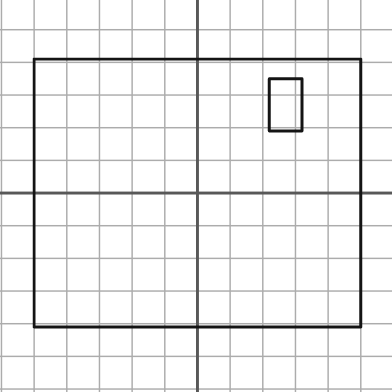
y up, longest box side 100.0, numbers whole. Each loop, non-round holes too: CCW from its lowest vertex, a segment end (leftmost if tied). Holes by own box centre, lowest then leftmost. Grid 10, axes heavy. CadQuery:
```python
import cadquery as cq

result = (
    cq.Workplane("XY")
    .moveTo(-50.0, -41.0)
    .lineTo(50.0, -41.0)
    .lineTo(50.0, 41.0)
    .lineTo(-50.0, 41.0)
    .close()
    .moveTo(22.0, 19.0)
    .lineTo(32.0, 19.0)
    .lineTo(32.0, 35.0)
    .lineTo(22.0, 35.0)
    .close()
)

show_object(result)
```